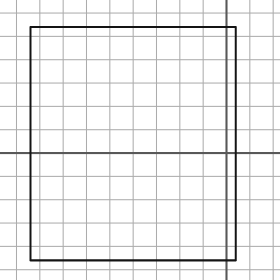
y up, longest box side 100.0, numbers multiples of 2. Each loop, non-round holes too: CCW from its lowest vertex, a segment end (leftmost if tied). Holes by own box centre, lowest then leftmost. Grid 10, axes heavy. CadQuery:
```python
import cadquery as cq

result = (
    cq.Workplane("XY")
    .moveTo(-84.0, -46.0)
    .lineTo(4.0, -46.0)
    .lineTo(4.0, 54.0)
    .lineTo(-84.0, 54.0)
    .close()
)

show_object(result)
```